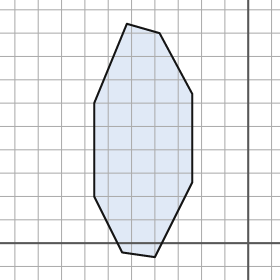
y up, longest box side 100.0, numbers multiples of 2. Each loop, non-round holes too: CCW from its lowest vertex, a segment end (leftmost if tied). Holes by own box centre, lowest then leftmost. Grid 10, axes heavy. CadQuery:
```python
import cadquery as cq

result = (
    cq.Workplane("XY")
    .moveTo(-40.0, -6.0)
    .lineTo(-24.0, 26.0)
    .lineTo(-24.0, 64.0)
    .lineTo(-38.0, 90.0)
    .lineTo(-52.0, 94.0)
    .lineTo(-66.0, 60.0)
    .lineTo(-66.0, 20.0)
    .lineTo(-54.0, -4.0)
    .close()
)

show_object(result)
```